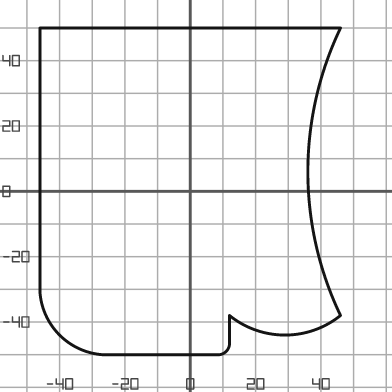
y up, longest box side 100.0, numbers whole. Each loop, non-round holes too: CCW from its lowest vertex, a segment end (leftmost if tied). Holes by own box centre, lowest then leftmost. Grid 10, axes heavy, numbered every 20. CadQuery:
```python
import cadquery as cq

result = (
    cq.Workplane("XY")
    .moveTo(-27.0, -50.0)
    .lineTo(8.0, -50.0)
    .threePointArc((11.0, -49.0), (12.0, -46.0))
    .lineTo(12.0, -38.0)
    .threePointArc((29.0, -44.0), (46.0, -38.0))
    .threePointArc((36.0, 6.0), (46.0, 50.0))
    .lineTo(-46.0, 50.0)
    .lineTo(-46.0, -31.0)
    .threePointArc((-40.0, -44.0), (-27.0, -50.0))
    .close()
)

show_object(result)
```